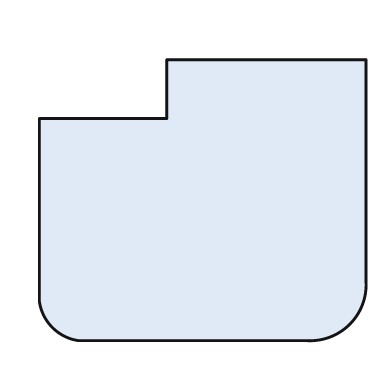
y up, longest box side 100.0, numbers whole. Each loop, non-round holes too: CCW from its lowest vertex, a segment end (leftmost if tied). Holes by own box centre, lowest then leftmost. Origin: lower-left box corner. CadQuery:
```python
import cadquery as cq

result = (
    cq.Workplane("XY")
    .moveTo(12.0, 0.0)
    .lineTo(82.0, 0.0)
    .threePointArc((95.0, 5.0), (100.0, 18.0))
    .lineTo(100.0, 86.0)
    .lineTo(39.0, 86.0)
    .lineTo(39.0, 68.0)
    .lineTo(0.0, 68.0)
    .lineTo(0.0, 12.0)
    .threePointArc((4.0, 4.0), (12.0, 0.0))
    .close()
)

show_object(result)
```